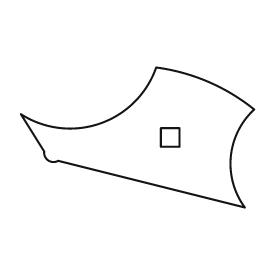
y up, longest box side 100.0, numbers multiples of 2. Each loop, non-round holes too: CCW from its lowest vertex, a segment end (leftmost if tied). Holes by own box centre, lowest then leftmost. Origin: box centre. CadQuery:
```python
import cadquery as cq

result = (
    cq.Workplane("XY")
    .moveTo(46.0, -30.0)
    .threePointArc((40.0, -8.0), (50.0, 12.0))
    .threePointArc((30.0, 24.0), (8.0, 30.0))
    .threePointArc((-16.0, 6.0), (-50.0, 10.0))
    .lineTo(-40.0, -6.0)
    .threePointArc((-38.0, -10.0), (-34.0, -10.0))
    .close()
    .moveTo(10.0, -4.0)
    .lineTo(18.0, -4.0)
    .lineTo(18.0, 4.0)
    .lineTo(10.0, 4.0)
    .close()
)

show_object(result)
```